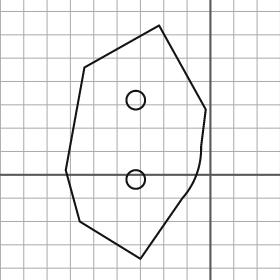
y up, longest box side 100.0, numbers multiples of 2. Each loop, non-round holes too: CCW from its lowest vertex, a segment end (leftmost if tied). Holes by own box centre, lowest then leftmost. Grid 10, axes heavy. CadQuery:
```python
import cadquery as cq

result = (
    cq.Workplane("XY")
    .moveTo(-30.0, -36.0)
    .lineTo(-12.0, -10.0)
    .threePointArc((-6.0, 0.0), (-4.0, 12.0))
    .lineTo(-2.0, 28.0)
    .lineTo(-22.0, 64.0)
    .lineTo(-54.0, 46.0)
    .lineTo(-62.0, 2.0)
    .lineTo(-56.0, -20.0)
    .close()
    .moveTo(-32.0, -2.0)
    .circle(4.0)
    .moveTo(-32.0, 32.0)
    .circle(4.0)
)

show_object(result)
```